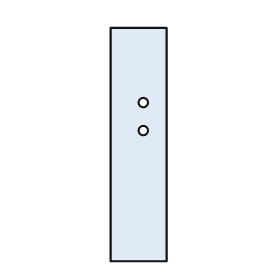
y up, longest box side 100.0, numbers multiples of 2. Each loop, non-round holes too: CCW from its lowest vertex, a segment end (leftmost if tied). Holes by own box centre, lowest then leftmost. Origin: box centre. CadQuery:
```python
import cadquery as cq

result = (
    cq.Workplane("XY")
    .moveTo(-12.0, -50.0)
    .lineTo(12.0, -50.0)
    .lineTo(12.0, 50.0)
    .lineTo(-12.0, 50.0)
    .close()
    .moveTo(2.0, 6.0)
    .circle(2.0)
    .moveTo(2.0, 18.0)
    .circle(2.0)
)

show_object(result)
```